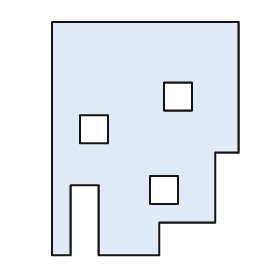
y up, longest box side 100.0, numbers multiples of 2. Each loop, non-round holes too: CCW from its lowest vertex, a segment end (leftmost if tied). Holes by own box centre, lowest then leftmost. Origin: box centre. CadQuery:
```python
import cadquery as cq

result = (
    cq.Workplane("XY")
    .moveTo(-40.0, -50.0)
    .lineTo(-32.0, -50.0)
    .lineTo(-32.0, -20.0)
    .lineTo(-20.0, -20.0)
    .lineTo(-20.0, -50.0)
    .lineTo(6.0, -50.0)
    .lineTo(6.0, -36.0)
    .lineTo(30.0, -36.0)
    .lineTo(30.0, -6.0)
    .lineTo(40.0, -6.0)
    .lineTo(40.0, 50.0)
    .lineTo(-40.0, 50.0)
    .close()
    .moveTo(2.0, -28.0)
    .lineTo(14.0, -28.0)
    .lineTo(14.0, -16.0)
    .lineTo(2.0, -16.0)
    .close()
    .moveTo(-28.0, -2.0)
    .lineTo(-16.0, -2.0)
    .lineTo(-16.0, 10.0)
    .lineTo(-28.0, 10.0)
    .close()
    .moveTo(8.0, 12.0)
    .lineTo(20.0, 12.0)
    .lineTo(20.0, 24.0)
    .lineTo(8.0, 24.0)
    .close()
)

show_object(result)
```